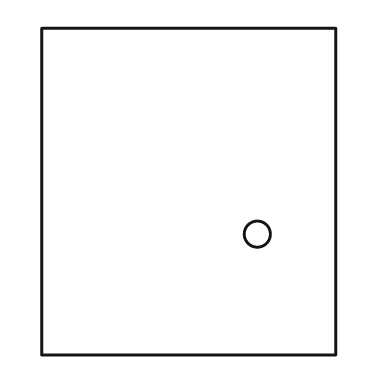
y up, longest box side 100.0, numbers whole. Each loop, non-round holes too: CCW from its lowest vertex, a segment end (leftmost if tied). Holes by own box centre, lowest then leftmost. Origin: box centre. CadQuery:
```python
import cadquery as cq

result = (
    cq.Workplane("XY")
    .moveTo(-45.0, -50.0)
    .lineTo(45.0, -50.0)
    .lineTo(45.0, 50.0)
    .lineTo(-45.0, 50.0)
    .close()
    .moveTo(21.0, -13.0)
    .circle(4.0)
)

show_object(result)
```